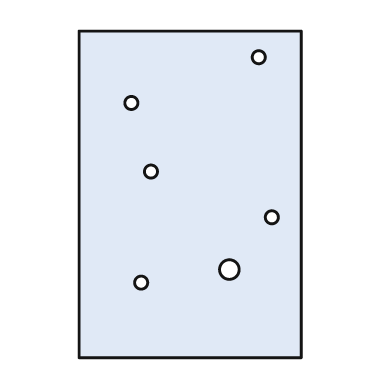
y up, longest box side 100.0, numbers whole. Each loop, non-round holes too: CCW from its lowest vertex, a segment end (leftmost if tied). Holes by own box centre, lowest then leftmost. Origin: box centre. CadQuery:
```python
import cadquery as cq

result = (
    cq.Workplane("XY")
    .moveTo(-34.0, -50.0)
    .lineTo(34.0, -50.0)
    .lineTo(34.0, 50.0)
    .lineTo(-34.0, 50.0)
    .close()
    .moveTo(-15.0, -27.0)
    .circle(2.0)
    .moveTo(12.0, -23.0)
    .circle(3.0)
    .moveTo(25.0, -7.0)
    .circle(2.0)
    .moveTo(-12.0, 7.0)
    .circle(2.0)
    .moveTo(-18.0, 28.0)
    .circle(2.0)
    .moveTo(21.0, 42.0)
    .circle(2.0)
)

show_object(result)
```